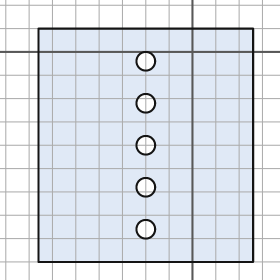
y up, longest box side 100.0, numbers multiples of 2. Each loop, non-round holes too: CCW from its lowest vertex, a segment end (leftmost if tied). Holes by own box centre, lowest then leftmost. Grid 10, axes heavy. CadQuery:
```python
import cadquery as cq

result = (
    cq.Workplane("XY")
    .moveTo(-66.0, -90.0)
    .lineTo(26.0, -90.0)
    .lineTo(26.0, 10.0)
    .lineTo(-66.0, 10.0)
    .close()
    .moveTo(-20.0, -76.0)
    .circle(4.0)
    .moveTo(-20.0, -58.0)
    .circle(4.0)
    .moveTo(-20.0, -40.0)
    .circle(4.0)
    .moveTo(-20.0, -22.0)
    .circle(4.0)
    .moveTo(-20.0, -4.0)
    .circle(4.0)
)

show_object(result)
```